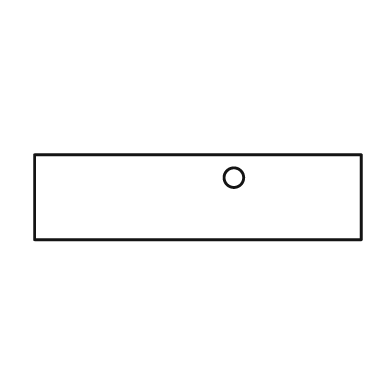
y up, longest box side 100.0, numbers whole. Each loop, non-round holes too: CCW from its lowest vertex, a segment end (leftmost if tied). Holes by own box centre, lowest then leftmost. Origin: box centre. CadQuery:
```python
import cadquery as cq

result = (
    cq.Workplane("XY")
    .moveTo(-50.0, -13.0)
    .lineTo(50.0, -13.0)
    .lineTo(50.0, 13.0)
    .lineTo(-50.0, 13.0)
    .close()
    .moveTo(11.0, 6.0)
    .circle(3.0)
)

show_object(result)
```